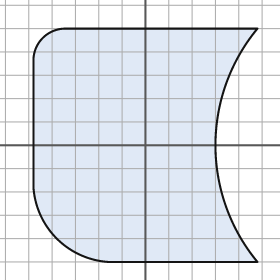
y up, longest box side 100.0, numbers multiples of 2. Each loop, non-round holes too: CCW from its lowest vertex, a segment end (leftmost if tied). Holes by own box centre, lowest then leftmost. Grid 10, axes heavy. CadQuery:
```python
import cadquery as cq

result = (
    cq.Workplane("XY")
    .moveTo(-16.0, -50.0)
    .lineTo(48.0, -50.0)
    .threePointArc((30.0, 0.0), (48.0, 50.0))
    .lineTo(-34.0, 50.0)
    .threePointArc((-44.0, 46.0), (-48.0, 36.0))
    .lineTo(-48.0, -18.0)
    .threePointArc((-38.0, -40.0), (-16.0, -50.0))
    .close()
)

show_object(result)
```